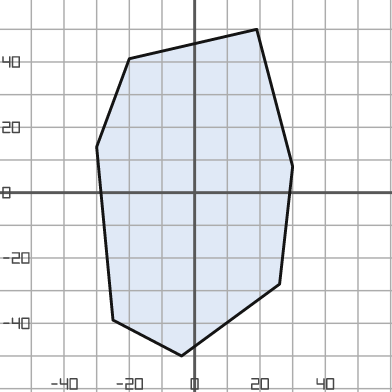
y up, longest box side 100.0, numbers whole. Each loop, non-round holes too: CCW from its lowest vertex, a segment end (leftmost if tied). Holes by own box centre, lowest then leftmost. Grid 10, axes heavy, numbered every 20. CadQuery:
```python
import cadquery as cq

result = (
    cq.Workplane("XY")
    .moveTo(-4.0, -50.0)
    .lineTo(26.0, -28.0)
    .lineTo(30.0, 8.0)
    .lineTo(19.0, 50.0)
    .lineTo(-20.0, 41.0)
    .lineTo(-30.0, 14.0)
    .lineTo(-25.0, -39.0)
    .close()
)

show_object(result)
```